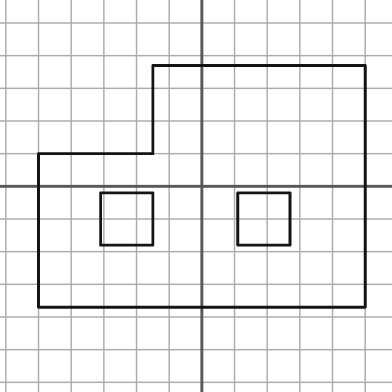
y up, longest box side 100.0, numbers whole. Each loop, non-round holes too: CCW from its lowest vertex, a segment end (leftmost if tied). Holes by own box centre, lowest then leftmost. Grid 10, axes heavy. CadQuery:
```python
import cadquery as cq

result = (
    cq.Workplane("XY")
    .moveTo(-50.0, -37.0)
    .lineTo(50.0, -37.0)
    .lineTo(50.0, 37.0)
    .lineTo(-15.0, 37.0)
    .lineTo(-15.0, 10.0)
    .lineTo(-50.0, 10.0)
    .close()
    .moveTo(-31.0, -18.0)
    .lineTo(-15.0, -18.0)
    .lineTo(-15.0, -2.0)
    .lineTo(-31.0, -2.0)
    .close()
    .moveTo(11.0, -18.0)
    .lineTo(27.0, -18.0)
    .lineTo(27.0, -2.0)
    .lineTo(11.0, -2.0)
    .close()
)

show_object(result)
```